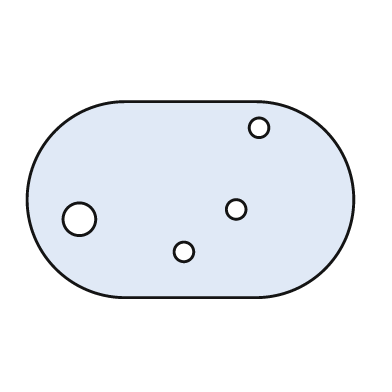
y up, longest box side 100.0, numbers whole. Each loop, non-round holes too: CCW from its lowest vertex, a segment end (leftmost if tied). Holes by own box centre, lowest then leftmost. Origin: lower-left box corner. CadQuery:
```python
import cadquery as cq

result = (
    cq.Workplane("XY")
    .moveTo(30.0, 0.0)
    .lineTo(70.0, 0.0)
    .threePointArc((100.0, 30.0), (70.0, 60.0))
    .lineTo(30.0, 60.0)
    .threePointArc((0.0, 30.0), (30.0, 0.0))
    .close()
    .moveTo(48.0, 14.0)
    .circle(3.0)
    .moveTo(16.0, 24.0)
    .circle(5.0)
    .moveTo(64.0, 27.0)
    .circle(3.0)
    .moveTo(71.0, 52.0)
    .circle(3.0)
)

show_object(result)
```